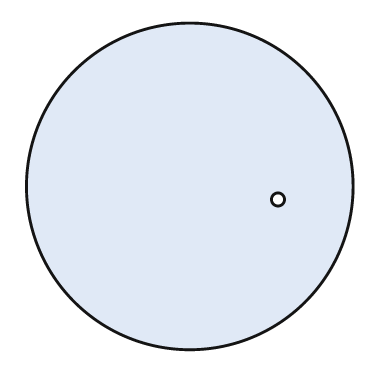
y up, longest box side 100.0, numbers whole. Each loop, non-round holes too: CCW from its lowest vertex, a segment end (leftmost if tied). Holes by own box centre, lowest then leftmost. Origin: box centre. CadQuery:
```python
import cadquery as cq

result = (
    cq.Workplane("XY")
    .moveTo(0.0, 0.0)
    .circle(50.0)
    .moveTo(27.0, -4.0)
    .circle(2.0)
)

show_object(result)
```